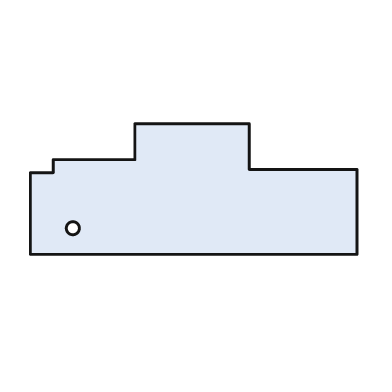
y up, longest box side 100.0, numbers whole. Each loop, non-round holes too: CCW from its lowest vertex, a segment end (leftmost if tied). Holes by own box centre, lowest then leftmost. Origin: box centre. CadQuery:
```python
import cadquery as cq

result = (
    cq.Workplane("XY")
    .moveTo(-50.0, -20.0)
    .lineTo(50.0, -20.0)
    .lineTo(50.0, 6.0)
    .lineTo(17.0, 6.0)
    .lineTo(17.0, 20.0)
    .lineTo(-18.0, 20.0)
    .lineTo(-18.0, 9.0)
    .lineTo(-43.0, 9.0)
    .lineTo(-43.0, 5.0)
    .lineTo(-50.0, 5.0)
    .close()
    .moveTo(-37.0, -12.0)
    .circle(2.0)
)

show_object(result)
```